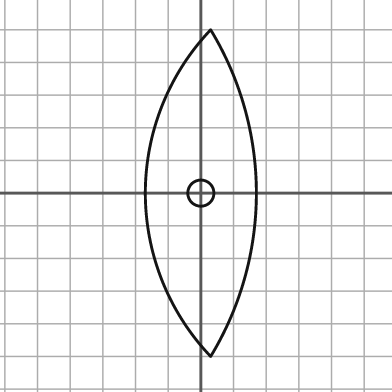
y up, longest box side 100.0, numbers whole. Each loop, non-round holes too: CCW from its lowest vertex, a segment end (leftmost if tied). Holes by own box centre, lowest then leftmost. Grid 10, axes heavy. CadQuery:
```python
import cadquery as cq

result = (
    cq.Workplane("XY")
    .moveTo(3.0, -50.0)
    .threePointArc((17.0, 0.0), (3.0, 50.0))
    .threePointArc((-17.0, 0.0), (3.0, -50.0))
    .close()
    .moveTo(0.0, 0.0)
    .circle(4.0)
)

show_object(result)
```